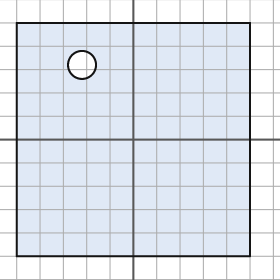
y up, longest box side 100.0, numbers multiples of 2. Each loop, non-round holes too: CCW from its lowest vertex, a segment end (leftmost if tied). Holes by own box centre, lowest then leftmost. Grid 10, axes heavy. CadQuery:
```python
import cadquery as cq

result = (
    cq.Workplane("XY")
    .moveTo(-50.0, -50.0)
    .lineTo(50.0, -50.0)
    .lineTo(50.0, 50.0)
    .lineTo(-50.0, 50.0)
    .close()
    .moveTo(-22.0, 32.0)
    .circle(6.0)
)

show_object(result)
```